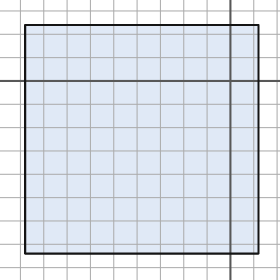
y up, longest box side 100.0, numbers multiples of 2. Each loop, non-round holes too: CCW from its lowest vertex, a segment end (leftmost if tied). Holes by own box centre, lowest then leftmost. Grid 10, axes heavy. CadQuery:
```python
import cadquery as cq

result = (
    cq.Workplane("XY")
    .moveTo(-88.0, -74.0)
    .lineTo(12.0, -74.0)
    .lineTo(12.0, 24.0)
    .lineTo(-88.0, 24.0)
    .close()
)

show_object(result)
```